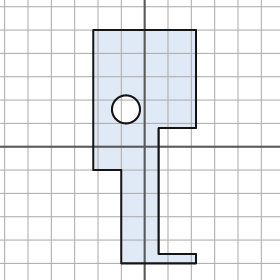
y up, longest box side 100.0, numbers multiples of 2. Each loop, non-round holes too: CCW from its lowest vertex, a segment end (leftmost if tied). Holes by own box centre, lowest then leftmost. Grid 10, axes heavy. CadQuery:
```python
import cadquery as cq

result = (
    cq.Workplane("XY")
    .moveTo(-10.0, -50.0)
    .lineTo(22.0, -50.0)
    .lineTo(22.0, -46.0)
    .lineTo(6.0, -46.0)
    .lineTo(6.0, 8.0)
    .lineTo(22.0, 8.0)
    .lineTo(22.0, 50.0)
    .lineTo(-22.0, 50.0)
    .lineTo(-22.0, -10.0)
    .lineTo(-10.0, -10.0)
    .close()
    .moveTo(-8.0, 16.0)
    .circle(6.0)
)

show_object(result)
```